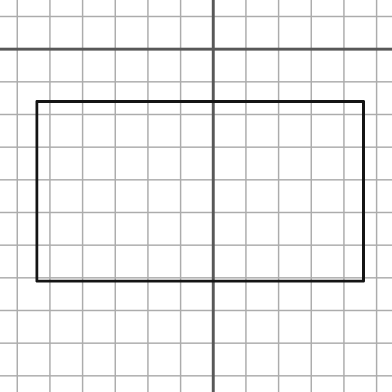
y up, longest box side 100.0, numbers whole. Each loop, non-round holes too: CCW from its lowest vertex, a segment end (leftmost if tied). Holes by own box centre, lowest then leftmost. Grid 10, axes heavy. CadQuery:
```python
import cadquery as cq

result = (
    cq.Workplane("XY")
    .moveTo(-54.0, -71.0)
    .lineTo(46.0, -71.0)
    .lineTo(46.0, -16.0)
    .lineTo(-54.0, -16.0)
    .close()
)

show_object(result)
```